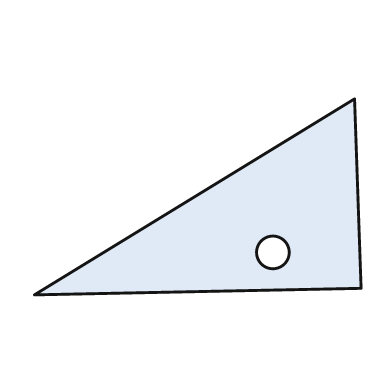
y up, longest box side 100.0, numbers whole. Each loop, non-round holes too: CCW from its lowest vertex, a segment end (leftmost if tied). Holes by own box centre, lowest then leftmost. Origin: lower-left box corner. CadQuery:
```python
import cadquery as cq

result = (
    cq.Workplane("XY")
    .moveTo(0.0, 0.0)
    .lineTo(100.0, 2.0)
    .lineTo(98.0, 60.0)
    .close()
    .moveTo(73.0, 13.0)
    .circle(5.0)
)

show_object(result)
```